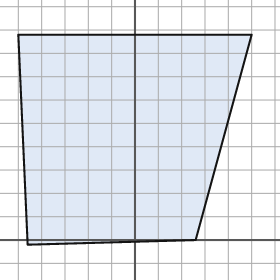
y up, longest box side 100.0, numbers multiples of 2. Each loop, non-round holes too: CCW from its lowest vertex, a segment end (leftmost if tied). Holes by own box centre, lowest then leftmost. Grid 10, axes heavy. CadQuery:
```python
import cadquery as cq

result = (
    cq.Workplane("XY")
    .moveTo(-46.0, -2.0)
    .lineTo(26.0, 0.0)
    .lineTo(50.0, 88.0)
    .lineTo(-50.0, 88.0)
    .close()
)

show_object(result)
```